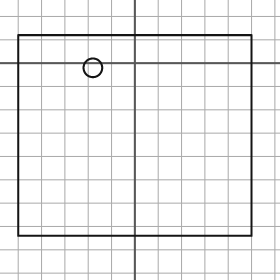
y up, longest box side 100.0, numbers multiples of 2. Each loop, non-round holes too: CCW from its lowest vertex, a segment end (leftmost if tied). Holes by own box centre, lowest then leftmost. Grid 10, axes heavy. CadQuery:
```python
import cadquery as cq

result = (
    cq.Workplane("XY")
    .moveTo(-50.0, -74.0)
    .lineTo(50.0, -74.0)
    .lineTo(50.0, 12.0)
    .lineTo(-50.0, 12.0)
    .close()
    .moveTo(-18.0, -2.0)
    .circle(4.0)
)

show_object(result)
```